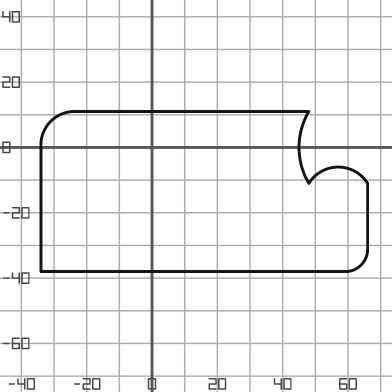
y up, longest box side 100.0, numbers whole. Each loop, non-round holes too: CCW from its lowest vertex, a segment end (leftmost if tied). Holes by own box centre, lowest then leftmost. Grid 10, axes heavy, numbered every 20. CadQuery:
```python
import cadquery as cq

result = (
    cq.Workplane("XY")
    .moveTo(-34.0, -38.0)
    .lineTo(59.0, -38.0)
    .threePointArc((64.0, -36.0), (66.0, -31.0))
    .lineTo(66.0, -11.0)
    .threePointArc((57.0, -6.0), (48.0, -11.0))
    .threePointArc((45.0, 0.0), (48.0, 11.0))
    .lineTo(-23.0, 11.0)
    .threePointArc((-31.0, 8.0), (-34.0, 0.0))
    .close()
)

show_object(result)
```